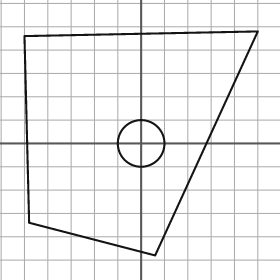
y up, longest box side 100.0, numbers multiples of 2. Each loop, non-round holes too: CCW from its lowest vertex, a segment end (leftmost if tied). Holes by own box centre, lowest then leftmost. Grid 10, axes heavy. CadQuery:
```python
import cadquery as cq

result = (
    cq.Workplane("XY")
    .moveTo(6.0, -48.0)
    .lineTo(50.0, 48.0)
    .lineTo(-50.0, 46.0)
    .lineTo(-48.0, -34.0)
    .close()
    .moveTo(0.0, 0.0)
    .circle(10.0)
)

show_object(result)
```